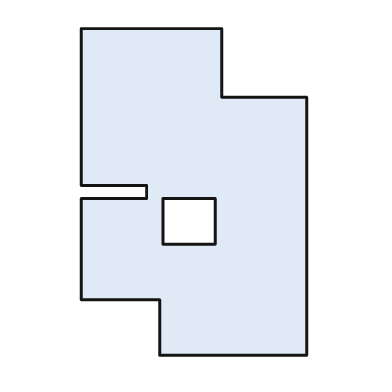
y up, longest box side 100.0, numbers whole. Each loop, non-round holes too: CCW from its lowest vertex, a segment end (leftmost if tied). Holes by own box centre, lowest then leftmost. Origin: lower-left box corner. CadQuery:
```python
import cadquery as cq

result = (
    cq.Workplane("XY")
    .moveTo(24.0, 0.0)
    .lineTo(69.0, 0.0)
    .lineTo(69.0, 79.0)
    .lineTo(43.0, 79.0)
    .lineTo(43.0, 100.0)
    .lineTo(0.0, 100.0)
    .lineTo(0.0, 52.0)
    .lineTo(20.0, 52.0)
    .lineTo(20.0, 48.0)
    .lineTo(0.0, 48.0)
    .lineTo(0.0, 17.0)
    .lineTo(24.0, 17.0)
    .close()
    .moveTo(25.0, 34.0)
    .lineTo(41.0, 34.0)
    .lineTo(41.0, 48.0)
    .lineTo(25.0, 48.0)
    .close()
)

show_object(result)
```